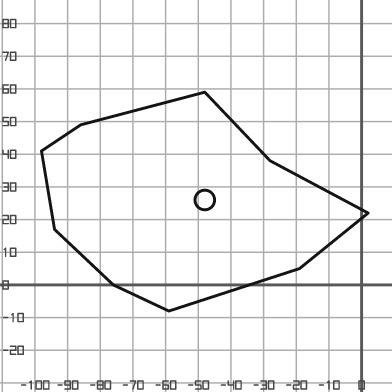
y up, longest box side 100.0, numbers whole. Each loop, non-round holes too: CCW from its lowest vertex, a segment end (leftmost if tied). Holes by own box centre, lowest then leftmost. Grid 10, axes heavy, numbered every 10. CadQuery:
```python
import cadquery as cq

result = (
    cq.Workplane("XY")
    .moveTo(-59.0, -8.0)
    .lineTo(-19.0, 5.0)
    .lineTo(2.0, 22.0)
    .lineTo(-28.0, 38.0)
    .lineTo(-48.0, 59.0)
    .lineTo(-86.0, 49.0)
    .lineTo(-98.0, 41.0)
    .lineTo(-94.0, 17.0)
    .lineTo(-76.0, 0.0)
    .close()
    .moveTo(-48.0, 26.0)
    .circle(3.0)
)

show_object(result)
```